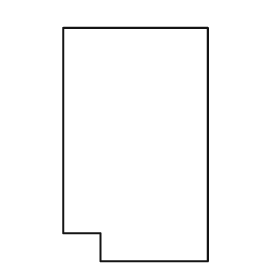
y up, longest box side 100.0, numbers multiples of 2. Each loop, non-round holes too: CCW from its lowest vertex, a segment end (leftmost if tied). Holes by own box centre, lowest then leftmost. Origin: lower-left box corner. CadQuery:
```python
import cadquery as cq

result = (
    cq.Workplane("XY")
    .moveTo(16.0, 0.0)
    .lineTo(62.0, 0.0)
    .lineTo(62.0, 100.0)
    .lineTo(0.0, 100.0)
    .lineTo(0.0, 12.0)
    .lineTo(16.0, 12.0)
    .close()
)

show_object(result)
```